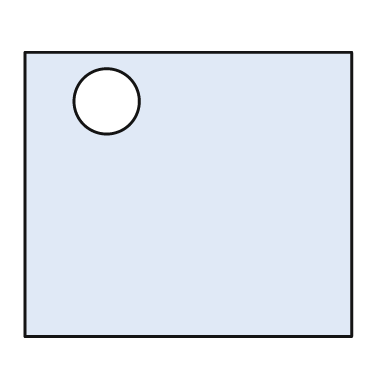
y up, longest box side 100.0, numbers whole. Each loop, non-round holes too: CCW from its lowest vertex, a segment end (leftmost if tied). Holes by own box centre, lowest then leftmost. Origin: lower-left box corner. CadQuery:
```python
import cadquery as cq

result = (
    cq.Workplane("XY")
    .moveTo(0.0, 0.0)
    .lineTo(100.0, 0.0)
    .lineTo(100.0, 87.0)
    .lineTo(0.0, 87.0)
    .close()
    .moveTo(25.0, 72.0)
    .circle(10.0)
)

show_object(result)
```